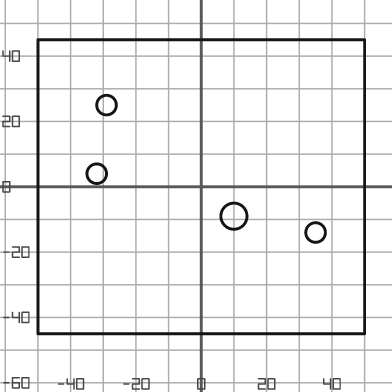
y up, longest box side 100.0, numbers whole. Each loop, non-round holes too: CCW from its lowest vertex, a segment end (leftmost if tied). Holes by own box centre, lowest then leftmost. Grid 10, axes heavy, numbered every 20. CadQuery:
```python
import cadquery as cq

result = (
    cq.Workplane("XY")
    .moveTo(-50.0, -45.0)
    .lineTo(50.0, -45.0)
    .lineTo(50.0, 45.0)
    .lineTo(-50.0, 45.0)
    .close()
    .moveTo(35.0, -14.0)
    .circle(3.0)
    .moveTo(10.0, -9.0)
    .circle(4.0)
    .moveTo(-32.0, 4.0)
    .circle(3.0)
    .moveTo(-29.0, 25.0)
    .circle(3.0)
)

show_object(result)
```